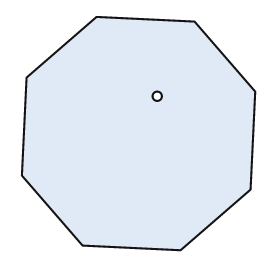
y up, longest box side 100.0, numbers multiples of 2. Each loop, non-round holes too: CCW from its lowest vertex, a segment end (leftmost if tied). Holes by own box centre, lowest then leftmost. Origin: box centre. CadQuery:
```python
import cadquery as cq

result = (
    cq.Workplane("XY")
    .moveTo(18.0, -50.0)
    .lineTo(48.0, -24.0)
    .lineTo(50.0, 18.0)
    .lineTo(24.0, 48.0)
    .lineTo(-18.0, 50.0)
    .lineTo(-48.0, 24.0)
    .lineTo(-50.0, -18.0)
    .lineTo(-24.0, -48.0)
    .close()
    .moveTo(8.0, 16.0)
    .circle(2.0)
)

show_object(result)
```